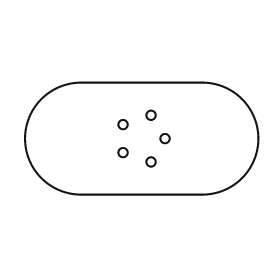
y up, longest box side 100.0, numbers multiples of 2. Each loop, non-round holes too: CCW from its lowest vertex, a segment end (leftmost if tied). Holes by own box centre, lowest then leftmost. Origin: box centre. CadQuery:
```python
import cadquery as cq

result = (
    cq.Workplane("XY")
    .moveTo(-26.0, -24.0)
    .lineTo(26.0, -24.0)
    .threePointArc((50.0, 0.0), (26.0, 24.0))
    .lineTo(-26.0, 24.0)
    .threePointArc((-50.0, 0.0), (-26.0, -24.0))
    .close()
    .moveTo(4.0, -10.0)
    .circle(2.0)
    .moveTo(-8.0, -6.0)
    .circle(2.0)
    .moveTo(10.0, 0.0)
    .circle(2.0)
    .moveTo(-8.0, 6.0)
    .circle(2.0)
    .moveTo(4.0, 10.0)
    .circle(2.0)
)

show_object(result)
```